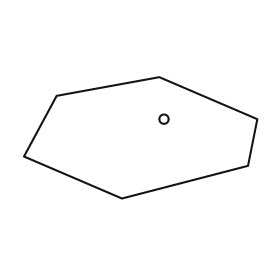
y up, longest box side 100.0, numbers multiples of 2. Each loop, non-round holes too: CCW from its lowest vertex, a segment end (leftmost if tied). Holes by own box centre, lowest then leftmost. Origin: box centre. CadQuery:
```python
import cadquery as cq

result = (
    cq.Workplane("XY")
    .moveTo(-8.0, -26.0)
    .lineTo(46.0, -12.0)
    .lineTo(50.0, 8.0)
    .lineTo(8.0, 26.0)
    .lineTo(-36.0, 18.0)
    .lineTo(-50.0, -8.0)
    .close()
    .moveTo(10.0, 8.0)
    .circle(2.0)
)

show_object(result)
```